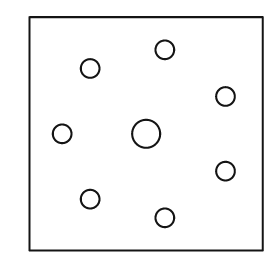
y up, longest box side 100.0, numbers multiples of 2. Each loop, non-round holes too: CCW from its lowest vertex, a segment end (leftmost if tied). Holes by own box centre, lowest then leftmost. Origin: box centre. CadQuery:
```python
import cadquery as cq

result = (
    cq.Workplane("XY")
    .moveTo(-50.0, -50.0)
    .lineTo(50.0, -50.0)
    .lineTo(50.0, 50.0)
    .lineTo(-50.0, 50.0)
    .close()
    .moveTo(8.0, -36.0)
    .circle(4.0)
    .moveTo(-24.0, -28.0)
    .circle(4.0)
    .moveTo(34.0, -16.0)
    .circle(4.0)
    .moveTo(-36.0, 0.0)
    .circle(4.0)
    .moveTo(0.0, 0.0)
    .circle(6.0)
    .moveTo(34.0, 16.0)
    .circle(4.0)
    .moveTo(-24.0, 28.0)
    .circle(4.0)
    .moveTo(8.0, 36.0)
    .circle(4.0)
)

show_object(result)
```